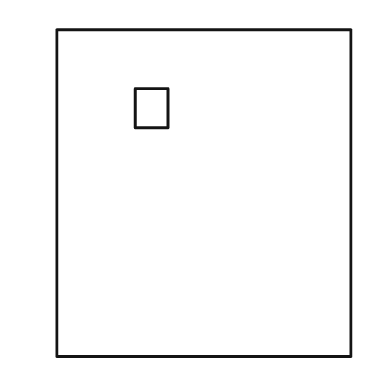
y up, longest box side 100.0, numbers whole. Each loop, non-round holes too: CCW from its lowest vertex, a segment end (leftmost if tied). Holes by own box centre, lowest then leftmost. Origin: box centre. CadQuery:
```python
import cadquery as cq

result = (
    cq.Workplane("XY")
    .moveTo(-45.0, -50.0)
    .lineTo(45.0, -50.0)
    .lineTo(45.0, 50.0)
    .lineTo(-45.0, 50.0)
    .close()
    .moveTo(-21.0, 20.0)
    .lineTo(-11.0, 20.0)
    .lineTo(-11.0, 32.0)
    .lineTo(-21.0, 32.0)
    .close()
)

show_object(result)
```